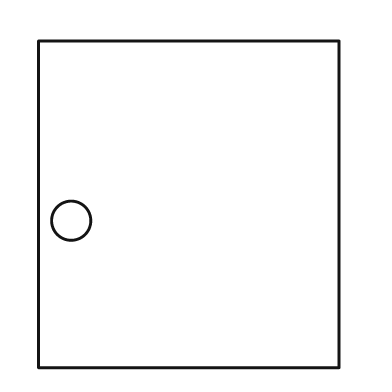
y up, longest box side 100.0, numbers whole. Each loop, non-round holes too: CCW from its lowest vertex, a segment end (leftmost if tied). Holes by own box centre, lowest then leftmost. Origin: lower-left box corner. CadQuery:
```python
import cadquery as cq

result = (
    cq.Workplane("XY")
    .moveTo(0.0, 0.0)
    .lineTo(92.0, 0.0)
    .lineTo(92.0, 100.0)
    .lineTo(0.0, 100.0)
    .close()
    .moveTo(10.0, 45.0)
    .circle(6.0)
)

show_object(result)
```